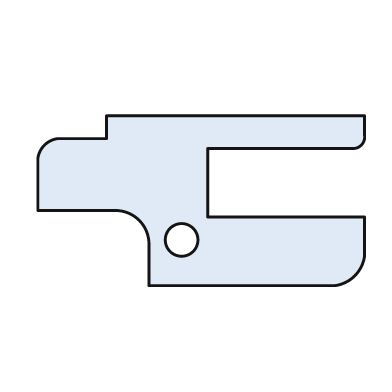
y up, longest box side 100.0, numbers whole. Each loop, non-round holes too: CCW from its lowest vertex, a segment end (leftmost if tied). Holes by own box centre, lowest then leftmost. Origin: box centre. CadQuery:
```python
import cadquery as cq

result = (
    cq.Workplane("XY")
    .moveTo(-16.0, -26.0)
    .lineTo(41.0, -26.0)
    .threePointArc((47.0, -23.0), (50.0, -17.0))
    .lineTo(50.0, -5.0)
    .lineTo(2.0, -5.0)
    .lineTo(2.0, 16.0)
    .lineTo(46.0, 16.0)
    .threePointArc((49.0, 17.0), (50.0, 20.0))
    .lineTo(50.0, 26.0)
    .lineTo(-29.0, 26.0)
    .lineTo(-29.0, 19.0)
    .lineTo(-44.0, 19.0)
    .threePointArc((-48.0, 17.0), (-50.0, 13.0))
    .lineTo(-50.0, -3.0)
    .lineTo(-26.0, -3.0)
    .threePointArc((-19.0, -6.0), (-16.0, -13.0))
    .close()
    .moveTo(-6.0, -12.0)
    .circle(5.0)
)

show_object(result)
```